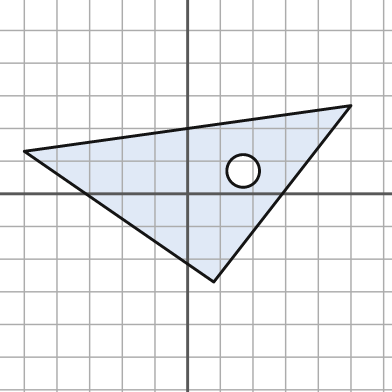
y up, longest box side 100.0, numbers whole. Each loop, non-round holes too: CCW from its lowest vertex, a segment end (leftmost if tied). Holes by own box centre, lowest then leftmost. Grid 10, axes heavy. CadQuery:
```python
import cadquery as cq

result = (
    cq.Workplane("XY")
    .moveTo(8.0, -27.0)
    .lineTo(50.0, 27.0)
    .lineTo(-50.0, 13.0)
    .close()
    .moveTo(17.0, 7.0)
    .circle(5.0)
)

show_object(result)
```